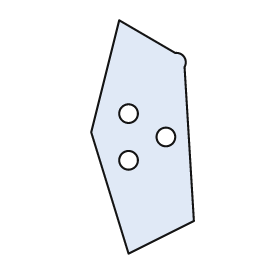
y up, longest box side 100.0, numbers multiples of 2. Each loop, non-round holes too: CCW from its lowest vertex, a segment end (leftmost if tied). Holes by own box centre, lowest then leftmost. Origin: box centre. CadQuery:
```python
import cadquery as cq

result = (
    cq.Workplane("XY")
    .moveTo(-6.0, -50.0)
    .lineTo(22.0, -36.0)
    .lineTo(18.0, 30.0)
    .threePointArc((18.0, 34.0), (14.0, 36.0))
    .lineTo(-10.0, 50.0)
    .lineTo(-22.0, 2.0)
    .close()
    .moveTo(-6.0, -10.0)
    .circle(4.0)
    .moveTo(10.0, 0.0)
    .circle(4.0)
    .moveTo(-6.0, 10.0)
    .circle(4.0)
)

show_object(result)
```